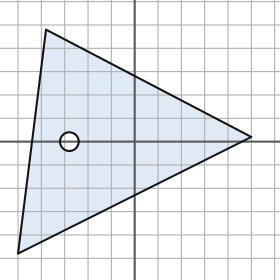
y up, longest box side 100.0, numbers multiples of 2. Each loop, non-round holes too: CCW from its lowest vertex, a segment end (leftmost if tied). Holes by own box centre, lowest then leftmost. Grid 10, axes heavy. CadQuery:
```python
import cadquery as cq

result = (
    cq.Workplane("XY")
    .moveTo(-50.0, -48.0)
    .lineTo(50.0, 2.0)
    .lineTo(-38.0, 48.0)
    .close()
    .moveTo(-28.0, 0.0)
    .circle(4.0)
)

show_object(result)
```